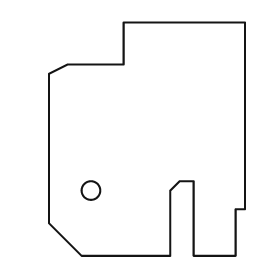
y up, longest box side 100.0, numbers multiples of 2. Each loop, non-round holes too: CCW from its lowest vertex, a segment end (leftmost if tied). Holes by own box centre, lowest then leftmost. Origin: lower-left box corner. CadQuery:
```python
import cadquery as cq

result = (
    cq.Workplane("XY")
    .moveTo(14.0, 0.0)
    .lineTo(52.0, 0.0)
    .lineTo(52.0, 28.0)
    .lineTo(56.0, 32.0)
    .lineTo(62.0, 32.0)
    .lineTo(62.0, 0.0)
    .lineTo(80.0, 0.0)
    .lineTo(80.0, 20.0)
    .lineTo(84.0, 20.0)
    .lineTo(84.0, 100.0)
    .lineTo(32.0, 100.0)
    .lineTo(32.0, 82.0)
    .lineTo(8.0, 82.0)
    .lineTo(0.0, 78.0)
    .lineTo(0.0, 14.0)
    .close()
    .moveTo(18.0, 28.0)
    .circle(4.0)
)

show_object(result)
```